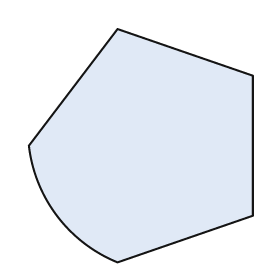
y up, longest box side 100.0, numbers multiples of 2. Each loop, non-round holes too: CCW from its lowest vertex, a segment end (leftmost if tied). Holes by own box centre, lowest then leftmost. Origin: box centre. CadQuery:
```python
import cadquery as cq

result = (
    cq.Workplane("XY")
    .moveTo(-10.0, -50.0)
    .lineTo(48.0, -30.0)
    .lineTo(48.0, 30.0)
    .lineTo(-10.0, 50.0)
    .lineTo(-48.0, 0.0)
    .threePointArc((-36.0, -30.0), (-10.0, -50.0))
    .close()
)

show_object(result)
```